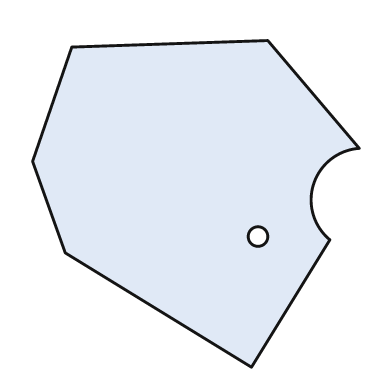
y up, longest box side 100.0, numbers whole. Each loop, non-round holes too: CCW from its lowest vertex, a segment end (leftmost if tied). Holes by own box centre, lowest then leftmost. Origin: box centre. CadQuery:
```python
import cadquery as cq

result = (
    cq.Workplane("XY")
    .moveTo(17.0, -50.0)
    .lineTo(41.0, -11.0)
    .threePointArc((36.0, 6.0), (50.0, 17.0))
    .lineTo(22.0, 50.0)
    .lineTo(-38.0, 48.0)
    .lineTo(-50.0, 13.0)
    .lineTo(-40.0, -15.0)
    .close()
    .moveTo(19.0, -10.0)
    .circle(3.0)
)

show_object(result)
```